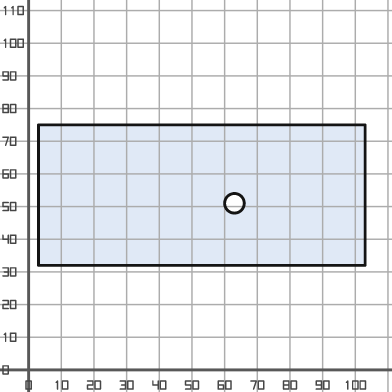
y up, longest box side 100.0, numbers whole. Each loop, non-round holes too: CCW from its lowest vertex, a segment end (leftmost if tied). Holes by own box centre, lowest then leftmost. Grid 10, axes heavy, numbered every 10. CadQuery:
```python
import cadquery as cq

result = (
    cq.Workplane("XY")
    .moveTo(3.0, 32.0)
    .lineTo(103.0, 32.0)
    .lineTo(103.0, 75.0)
    .lineTo(3.0, 75.0)
    .close()
    .moveTo(63.0, 51.0)
    .circle(3.0)
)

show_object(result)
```